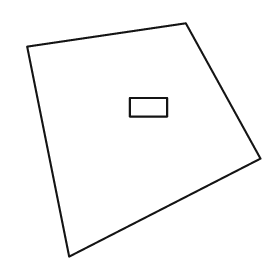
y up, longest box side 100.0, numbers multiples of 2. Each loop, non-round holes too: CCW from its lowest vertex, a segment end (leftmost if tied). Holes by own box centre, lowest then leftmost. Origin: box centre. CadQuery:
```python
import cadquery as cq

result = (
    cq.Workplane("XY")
    .moveTo(-32.0, -50.0)
    .lineTo(50.0, -8.0)
    .lineTo(18.0, 50.0)
    .lineTo(-50.0, 40.0)
    .close()
    .moveTo(-6.0, 10.0)
    .lineTo(10.0, 10.0)
    .lineTo(10.0, 18.0)
    .lineTo(-6.0, 18.0)
    .close()
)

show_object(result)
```